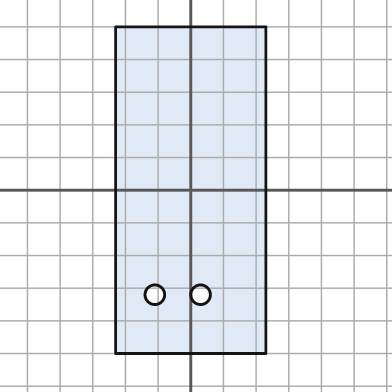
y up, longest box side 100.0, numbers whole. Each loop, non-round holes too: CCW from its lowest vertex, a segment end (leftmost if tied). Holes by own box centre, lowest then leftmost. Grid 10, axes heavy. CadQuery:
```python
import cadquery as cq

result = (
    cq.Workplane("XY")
    .moveTo(-23.0, -50.0)
    .lineTo(23.0, -50.0)
    .lineTo(23.0, 50.0)
    .lineTo(-23.0, 50.0)
    .close()
    .moveTo(-11.0, -32.0)
    .circle(3.0)
    .moveTo(3.0, -32.0)
    .circle(3.0)
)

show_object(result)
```